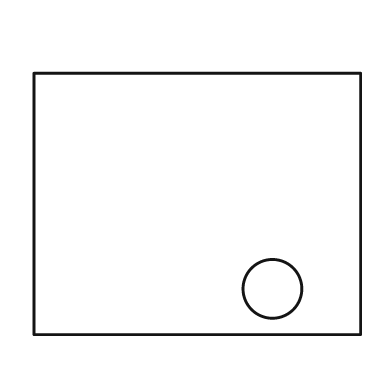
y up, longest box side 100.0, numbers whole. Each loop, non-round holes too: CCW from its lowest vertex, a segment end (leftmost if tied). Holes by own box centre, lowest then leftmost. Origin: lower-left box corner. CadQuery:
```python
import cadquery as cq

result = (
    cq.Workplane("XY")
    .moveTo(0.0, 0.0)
    .lineTo(100.0, 0.0)
    .lineTo(100.0, 80.0)
    .lineTo(0.0, 80.0)
    .close()
    .moveTo(73.0, 14.0)
    .circle(9.0)
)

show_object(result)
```